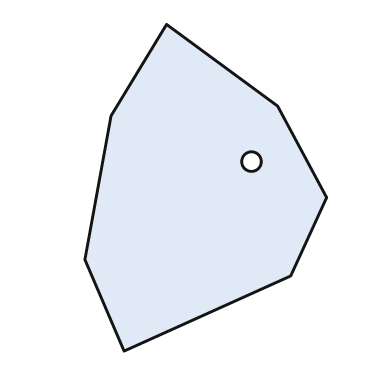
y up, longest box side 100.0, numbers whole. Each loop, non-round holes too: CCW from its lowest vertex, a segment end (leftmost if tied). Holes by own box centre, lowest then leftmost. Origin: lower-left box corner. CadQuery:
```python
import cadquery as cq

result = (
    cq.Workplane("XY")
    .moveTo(12.0, 0.0)
    .lineTo(63.0, 23.0)
    .lineTo(74.0, 47.0)
    .lineTo(59.0, 75.0)
    .lineTo(25.0, 100.0)
    .lineTo(8.0, 72.0)
    .lineTo(0.0, 28.0)
    .close()
    .moveTo(51.0, 58.0)
    .circle(3.0)
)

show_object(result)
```